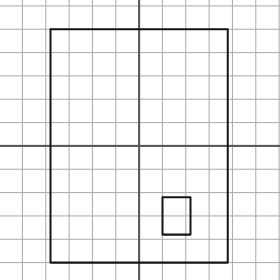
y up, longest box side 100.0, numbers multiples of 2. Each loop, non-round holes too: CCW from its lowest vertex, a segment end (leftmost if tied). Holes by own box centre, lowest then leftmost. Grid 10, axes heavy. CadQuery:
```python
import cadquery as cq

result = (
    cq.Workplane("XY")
    .moveTo(-38.0, -50.0)
    .lineTo(38.0, -50.0)
    .lineTo(38.0, 50.0)
    .lineTo(-38.0, 50.0)
    .close()
    .moveTo(10.0, -38.0)
    .lineTo(22.0, -38.0)
    .lineTo(22.0, -22.0)
    .lineTo(10.0, -22.0)
    .close()
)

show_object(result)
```